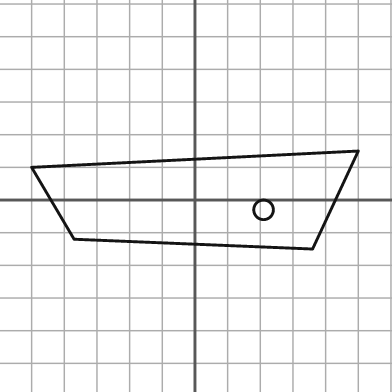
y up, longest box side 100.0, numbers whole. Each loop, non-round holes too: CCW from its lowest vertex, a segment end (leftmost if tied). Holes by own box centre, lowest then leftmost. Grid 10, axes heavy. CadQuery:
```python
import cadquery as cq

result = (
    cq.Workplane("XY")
    .moveTo(36.0, -15.0)
    .lineTo(50.0, 15.0)
    .lineTo(-50.0, 10.0)
    .lineTo(-37.0, -12.0)
    .close()
    .moveTo(21.0, -3.0)
    .circle(3.0)
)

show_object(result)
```